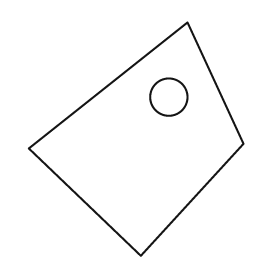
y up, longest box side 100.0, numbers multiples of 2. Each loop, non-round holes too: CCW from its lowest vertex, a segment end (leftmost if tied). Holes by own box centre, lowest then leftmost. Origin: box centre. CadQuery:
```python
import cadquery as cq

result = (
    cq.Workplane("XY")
    .moveTo(2.0, -50.0)
    .lineTo(46.0, -2.0)
    .lineTo(22.0, 50.0)
    .lineTo(-46.0, -4.0)
    .close()
    .moveTo(14.0, 18.0)
    .circle(8.0)
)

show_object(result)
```